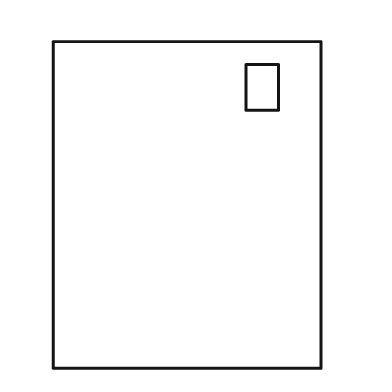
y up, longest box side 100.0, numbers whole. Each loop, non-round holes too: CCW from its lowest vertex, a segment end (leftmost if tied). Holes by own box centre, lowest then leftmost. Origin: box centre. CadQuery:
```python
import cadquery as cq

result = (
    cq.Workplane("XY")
    .moveTo(-41.0, -50.0)
    .lineTo(41.0, -50.0)
    .lineTo(41.0, 50.0)
    .lineTo(-41.0, 50.0)
    .close()
    .moveTo(18.0, 29.0)
    .lineTo(28.0, 29.0)
    .lineTo(28.0, 43.0)
    .lineTo(18.0, 43.0)
    .close()
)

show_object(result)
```